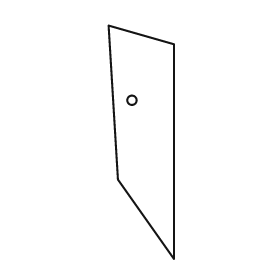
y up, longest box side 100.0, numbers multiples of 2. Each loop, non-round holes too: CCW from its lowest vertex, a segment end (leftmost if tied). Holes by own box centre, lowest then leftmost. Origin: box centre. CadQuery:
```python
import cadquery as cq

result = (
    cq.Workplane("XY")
    .moveTo(14.0, -50.0)
    .lineTo(14.0, 42.0)
    .lineTo(-14.0, 50.0)
    .lineTo(-10.0, -16.0)
    .close()
    .moveTo(-4.0, 18.0)
    .circle(2.0)
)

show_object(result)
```